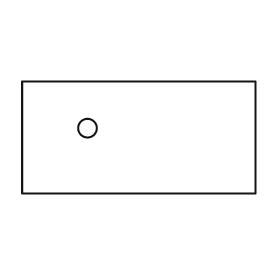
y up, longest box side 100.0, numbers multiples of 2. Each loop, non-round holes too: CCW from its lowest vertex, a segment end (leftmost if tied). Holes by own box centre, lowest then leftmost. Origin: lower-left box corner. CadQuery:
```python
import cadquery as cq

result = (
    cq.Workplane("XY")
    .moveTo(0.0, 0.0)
    .lineTo(100.0, 0.0)
    .lineTo(100.0, 48.0)
    .lineTo(0.0, 48.0)
    .close()
    .moveTo(28.0, 28.0)
    .circle(4.0)
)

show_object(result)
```